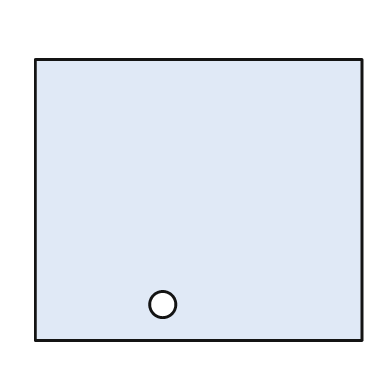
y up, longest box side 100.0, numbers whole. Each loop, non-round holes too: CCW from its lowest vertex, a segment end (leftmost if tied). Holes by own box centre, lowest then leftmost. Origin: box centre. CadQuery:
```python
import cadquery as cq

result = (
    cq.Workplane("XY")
    .moveTo(-50.0, -43.0)
    .lineTo(50.0, -43.0)
    .lineTo(50.0, 43.0)
    .lineTo(-50.0, 43.0)
    .close()
    .moveTo(-11.0, -32.0)
    .circle(4.0)
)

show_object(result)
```